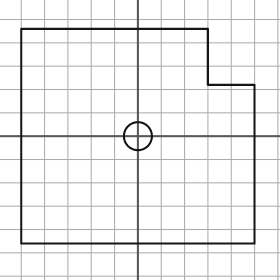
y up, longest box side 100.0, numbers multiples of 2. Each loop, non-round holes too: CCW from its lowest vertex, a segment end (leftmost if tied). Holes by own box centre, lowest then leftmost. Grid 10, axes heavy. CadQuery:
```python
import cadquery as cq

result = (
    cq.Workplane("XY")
    .moveTo(-50.0, -46.0)
    .lineTo(50.0, -46.0)
    .lineTo(50.0, 22.0)
    .lineTo(30.0, 22.0)
    .lineTo(30.0, 46.0)
    .lineTo(-50.0, 46.0)
    .close()
    .moveTo(0.0, 0.0)
    .circle(6.0)
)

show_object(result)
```